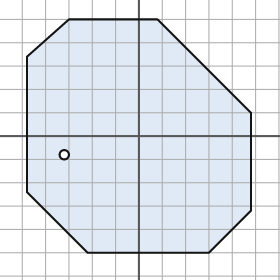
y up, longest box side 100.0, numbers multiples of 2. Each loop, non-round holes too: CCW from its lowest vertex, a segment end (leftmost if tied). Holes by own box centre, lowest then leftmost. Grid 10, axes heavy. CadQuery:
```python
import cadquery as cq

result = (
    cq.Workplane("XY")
    .moveTo(-22.0, -50.0)
    .lineTo(30.0, -50.0)
    .lineTo(48.0, -32.0)
    .lineTo(48.0, 10.0)
    .lineTo(8.0, 50.0)
    .lineTo(-30.0, 50.0)
    .lineTo(-48.0, 34.0)
    .lineTo(-48.0, -24.0)
    .close()
    .moveTo(-32.0, -8.0)
    .circle(2.0)
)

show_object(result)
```